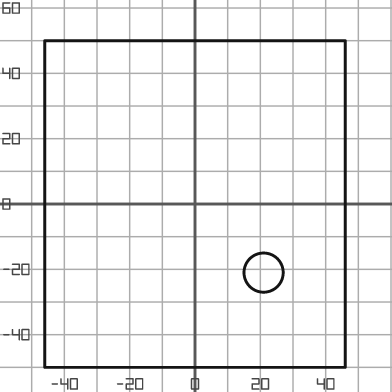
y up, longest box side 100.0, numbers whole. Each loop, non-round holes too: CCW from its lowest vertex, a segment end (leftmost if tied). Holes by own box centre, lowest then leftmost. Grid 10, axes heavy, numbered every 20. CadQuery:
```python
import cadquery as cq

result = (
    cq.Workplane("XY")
    .moveTo(-46.0, -50.0)
    .lineTo(46.0, -50.0)
    .lineTo(46.0, 50.0)
    .lineTo(-46.0, 50.0)
    .close()
    .moveTo(21.0, -21.0)
    .circle(6.0)
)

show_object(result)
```